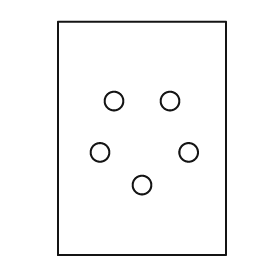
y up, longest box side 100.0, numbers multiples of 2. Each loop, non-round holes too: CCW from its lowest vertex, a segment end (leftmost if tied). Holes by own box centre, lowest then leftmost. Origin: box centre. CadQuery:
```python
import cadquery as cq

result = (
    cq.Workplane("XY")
    .moveTo(-36.0, -50.0)
    .lineTo(36.0, -50.0)
    .lineTo(36.0, 50.0)
    .lineTo(-36.0, 50.0)
    .close()
    .moveTo(0.0, -20.0)
    .circle(4.0)
    .moveTo(-18.0, -6.0)
    .circle(4.0)
    .moveTo(20.0, -6.0)
    .circle(4.0)
    .moveTo(-12.0, 16.0)
    .circle(4.0)
    .moveTo(12.0, 16.0)
    .circle(4.0)
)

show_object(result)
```